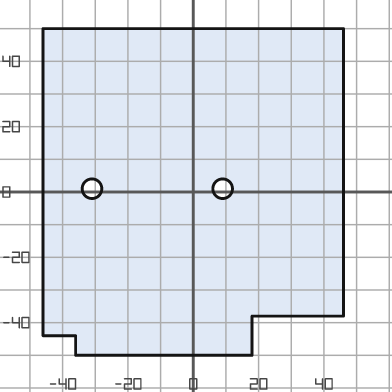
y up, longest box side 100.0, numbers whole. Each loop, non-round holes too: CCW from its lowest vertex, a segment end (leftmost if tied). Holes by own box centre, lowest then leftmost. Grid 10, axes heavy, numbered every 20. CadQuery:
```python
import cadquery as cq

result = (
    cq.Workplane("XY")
    .moveTo(-36.0, -50.0)
    .lineTo(18.0, -50.0)
    .lineTo(18.0, -38.0)
    .lineTo(46.0, -38.0)
    .lineTo(46.0, 50.0)
    .lineTo(-46.0, 50.0)
    .lineTo(-46.0, -44.0)
    .lineTo(-36.0, -44.0)
    .close()
    .moveTo(-31.0, 1.0)
    .circle(3.0)
    .moveTo(9.0, 1.0)
    .circle(3.0)
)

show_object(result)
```